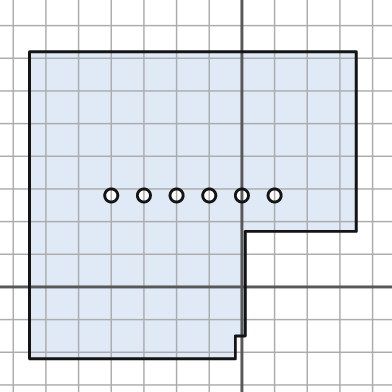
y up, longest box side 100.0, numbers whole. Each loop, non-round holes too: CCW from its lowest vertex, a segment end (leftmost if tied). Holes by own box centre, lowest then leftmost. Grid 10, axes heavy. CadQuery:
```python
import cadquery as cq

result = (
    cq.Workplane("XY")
    .moveTo(-65.0, -22.0)
    .lineTo(-2.0, -22.0)
    .lineTo(-2.0, -15.0)
    .lineTo(1.0, -15.0)
    .lineTo(1.0, 17.0)
    .lineTo(35.0, 17.0)
    .lineTo(35.0, 72.0)
    .lineTo(-65.0, 72.0)
    .close()
    .moveTo(-40.0, 28.0)
    .circle(2.0)
    .moveTo(-30.0, 28.0)
    .circle(2.0)
    .moveTo(-20.0, 28.0)
    .circle(2.0)
    .moveTo(-10.0, 28.0)
    .circle(2.0)
    .moveTo(0.0, 28.0)
    .circle(2.0)
    .moveTo(10.0, 28.0)
    .circle(2.0)
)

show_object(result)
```